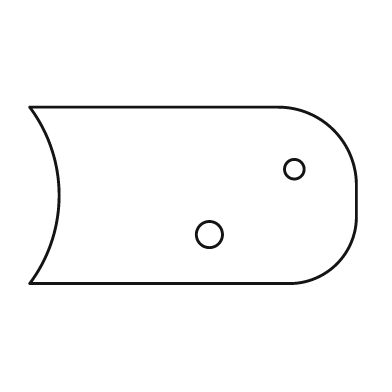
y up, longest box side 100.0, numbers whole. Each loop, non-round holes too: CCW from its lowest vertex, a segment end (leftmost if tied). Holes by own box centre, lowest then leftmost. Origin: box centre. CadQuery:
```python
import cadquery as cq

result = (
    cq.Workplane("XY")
    .moveTo(-50.0, -27.0)
    .lineTo(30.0, -27.0)
    .threePointArc((44.0, -21.0), (50.0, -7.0))
    .lineTo(50.0, 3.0)
    .threePointArc((43.0, 20.0), (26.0, 27.0))
    .lineTo(-50.0, 27.0)
    .threePointArc((-41.0, 0.0), (-50.0, -27.0))
    .close()
    .moveTo(5.0, -12.0)
    .circle(4.0)
    .moveTo(31.0, 8.0)
    .circle(3.0)
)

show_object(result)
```